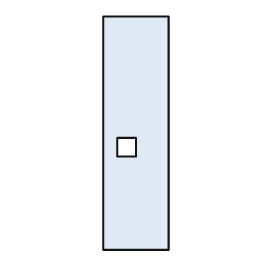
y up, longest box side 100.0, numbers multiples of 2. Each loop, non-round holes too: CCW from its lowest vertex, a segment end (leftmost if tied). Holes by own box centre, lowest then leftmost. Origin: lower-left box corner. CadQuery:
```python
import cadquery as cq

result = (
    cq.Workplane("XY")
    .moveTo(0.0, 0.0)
    .lineTo(28.0, 0.0)
    .lineTo(28.0, 100.0)
    .lineTo(0.0, 100.0)
    .close()
    .moveTo(6.0, 40.0)
    .lineTo(14.0, 40.0)
    .lineTo(14.0, 48.0)
    .lineTo(6.0, 48.0)
    .close()
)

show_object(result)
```